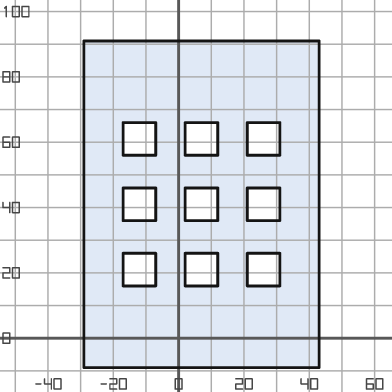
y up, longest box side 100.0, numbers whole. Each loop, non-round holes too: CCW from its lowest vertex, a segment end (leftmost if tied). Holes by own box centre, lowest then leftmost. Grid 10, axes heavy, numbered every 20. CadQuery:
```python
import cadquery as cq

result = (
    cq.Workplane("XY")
    .moveTo(-29.0, -9.0)
    .lineTo(43.0, -9.0)
    .lineTo(43.0, 91.0)
    .lineTo(-29.0, 91.0)
    .close()
    .moveTo(-17.0, 16.0)
    .lineTo(-7.0, 16.0)
    .lineTo(-7.0, 26.0)
    .lineTo(-17.0, 26.0)
    .close()
    .moveTo(2.0, 16.0)
    .lineTo(12.0, 16.0)
    .lineTo(12.0, 26.0)
    .lineTo(2.0, 26.0)
    .close()
    .moveTo(21.0, 16.0)
    .lineTo(31.0, 16.0)
    .lineTo(31.0, 26.0)
    .lineTo(21.0, 26.0)
    .close()
    .moveTo(-17.0, 36.0)
    .lineTo(-7.0, 36.0)
    .lineTo(-7.0, 46.0)
    .lineTo(-17.0, 46.0)
    .close()
    .moveTo(2.0, 36.0)
    .lineTo(12.0, 36.0)
    .lineTo(12.0, 46.0)
    .lineTo(2.0, 46.0)
    .close()
    .moveTo(21.0, 36.0)
    .lineTo(31.0, 36.0)
    .lineTo(31.0, 46.0)
    .lineTo(21.0, 46.0)
    .close()
    .moveTo(-17.0, 56.0)
    .lineTo(-7.0, 56.0)
    .lineTo(-7.0, 66.0)
    .lineTo(-17.0, 66.0)
    .close()
    .moveTo(2.0, 56.0)
    .lineTo(12.0, 56.0)
    .lineTo(12.0, 66.0)
    .lineTo(2.0, 66.0)
    .close()
    .moveTo(21.0, 56.0)
    .lineTo(31.0, 56.0)
    .lineTo(31.0, 66.0)
    .lineTo(21.0, 66.0)
    .close()
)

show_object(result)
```